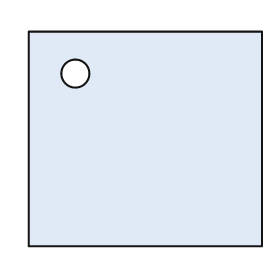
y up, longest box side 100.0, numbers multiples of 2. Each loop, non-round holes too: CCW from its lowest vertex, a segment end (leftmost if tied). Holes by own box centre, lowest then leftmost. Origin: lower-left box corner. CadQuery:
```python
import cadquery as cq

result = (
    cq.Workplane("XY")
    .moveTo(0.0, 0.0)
    .lineTo(100.0, 0.0)
    .lineTo(100.0, 92.0)
    .lineTo(0.0, 92.0)
    .close()
    .moveTo(20.0, 74.0)
    .circle(6.0)
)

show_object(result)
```